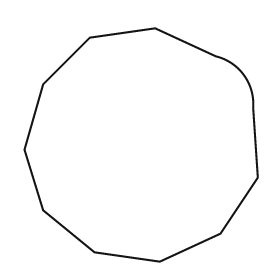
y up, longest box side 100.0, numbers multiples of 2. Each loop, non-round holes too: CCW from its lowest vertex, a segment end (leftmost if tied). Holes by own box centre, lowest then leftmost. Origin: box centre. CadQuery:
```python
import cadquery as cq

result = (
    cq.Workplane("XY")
    .moveTo(8.0, -50.0)
    .lineTo(34.0, -38.0)
    .lineTo(50.0, -14.0)
    .lineTo(48.0, 16.0)
    .threePointArc((44.0, 30.0), (32.0, 38.0))
    .lineTo(6.0, 50.0)
    .lineTo(-22.0, 46.0)
    .lineTo(-42.0, 26.0)
    .lineTo(-50.0, -2.0)
    .lineTo(-42.0, -28.0)
    .lineTo(-20.0, -46.0)
    .close()
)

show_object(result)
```